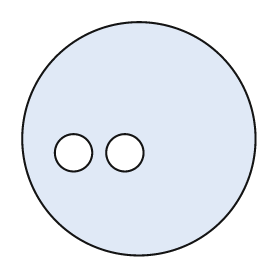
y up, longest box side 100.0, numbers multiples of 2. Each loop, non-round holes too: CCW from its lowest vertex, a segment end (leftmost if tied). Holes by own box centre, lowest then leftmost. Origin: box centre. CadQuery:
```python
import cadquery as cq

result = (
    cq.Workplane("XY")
    .moveTo(0.0, 0.0)
    .circle(50.0)
    .moveTo(-28.0, -6.0)
    .circle(8.0)
    .moveTo(-6.0, -6.0)
    .circle(8.0)
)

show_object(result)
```